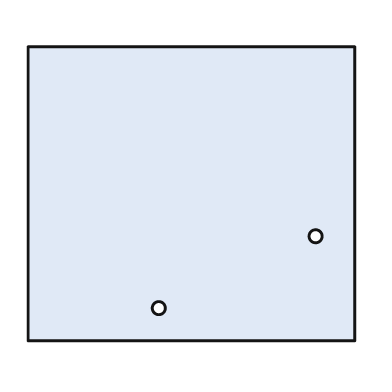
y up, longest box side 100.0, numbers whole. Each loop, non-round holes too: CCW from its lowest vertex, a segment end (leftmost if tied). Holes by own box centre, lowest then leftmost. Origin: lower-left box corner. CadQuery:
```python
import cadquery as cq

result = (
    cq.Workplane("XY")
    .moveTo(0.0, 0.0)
    .lineTo(100.0, 0.0)
    .lineTo(100.0, 90.0)
    .lineTo(0.0, 90.0)
    .close()
    .moveTo(40.0, 10.0)
    .circle(2.0)
    .moveTo(88.0, 32.0)
    .circle(2.0)
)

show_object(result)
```